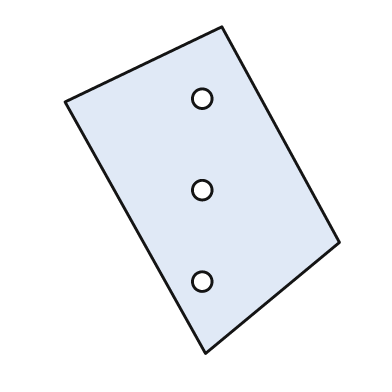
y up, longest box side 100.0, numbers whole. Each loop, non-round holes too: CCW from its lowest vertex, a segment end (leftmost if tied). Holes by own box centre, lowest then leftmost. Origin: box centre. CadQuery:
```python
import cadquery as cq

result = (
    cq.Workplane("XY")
    .moveTo(1.0, -50.0)
    .lineTo(42.0, -16.0)
    .lineTo(6.0, 50.0)
    .lineTo(-42.0, 27.0)
    .close()
    .moveTo(0.0, -28.0)
    .circle(3.0)
    .moveTo(0.0, 0.0)
    .circle(3.0)
    .moveTo(0.0, 28.0)
    .circle(3.0)
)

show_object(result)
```